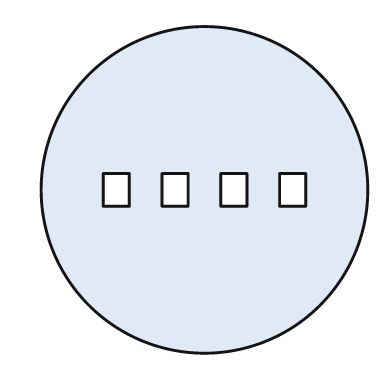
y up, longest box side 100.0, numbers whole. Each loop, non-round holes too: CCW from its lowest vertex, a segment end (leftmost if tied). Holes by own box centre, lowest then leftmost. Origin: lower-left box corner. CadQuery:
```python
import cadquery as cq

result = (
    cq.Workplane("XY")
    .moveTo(50.0, 50.0)
    .circle(50.0)
    .moveTo(19.0, 45.0)
    .lineTo(27.0, 45.0)
    .lineTo(27.0, 55.0)
    .lineTo(19.0, 55.0)
    .close()
    .moveTo(37.0, 45.0)
    .lineTo(45.0, 45.0)
    .lineTo(45.0, 55.0)
    .lineTo(37.0, 55.0)
    .close()
    .moveTo(55.0, 45.0)
    .lineTo(63.0, 45.0)
    .lineTo(63.0, 55.0)
    .lineTo(55.0, 55.0)
    .close()
    .moveTo(73.0, 45.0)
    .lineTo(81.0, 45.0)
    .lineTo(81.0, 55.0)
    .lineTo(73.0, 55.0)
    .close()
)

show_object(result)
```